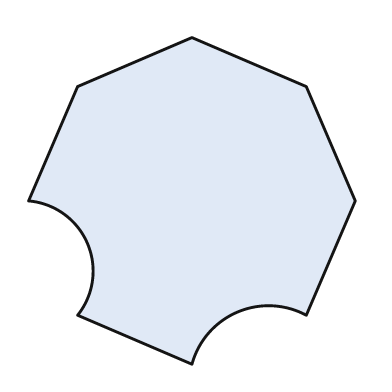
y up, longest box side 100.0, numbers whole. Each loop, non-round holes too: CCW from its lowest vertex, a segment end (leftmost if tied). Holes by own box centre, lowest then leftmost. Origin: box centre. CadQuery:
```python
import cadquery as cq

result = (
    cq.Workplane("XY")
    .moveTo(0.0, -50.0)
    .threePointArc((14.0, -34.0), (35.0, -35.0))
    .lineTo(50.0, 0.0)
    .lineTo(35.0, 35.0)
    .lineTo(0.0, 50.0)
    .lineTo(-35.0, 35.0)
    .lineTo(-50.0, 0.0)
    .threePointArc((-32.0, -13.0), (-35.0, -35.0))
    .close()
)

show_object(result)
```